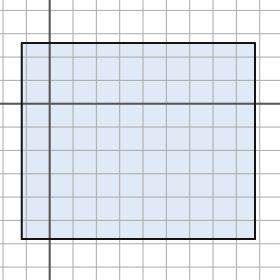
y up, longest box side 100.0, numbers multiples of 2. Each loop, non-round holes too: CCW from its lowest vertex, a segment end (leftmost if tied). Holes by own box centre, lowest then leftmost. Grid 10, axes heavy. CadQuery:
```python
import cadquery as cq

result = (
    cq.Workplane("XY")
    .moveTo(-12.0, -58.0)
    .lineTo(88.0, -58.0)
    .lineTo(88.0, 26.0)
    .lineTo(-12.0, 26.0)
    .close()
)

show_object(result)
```